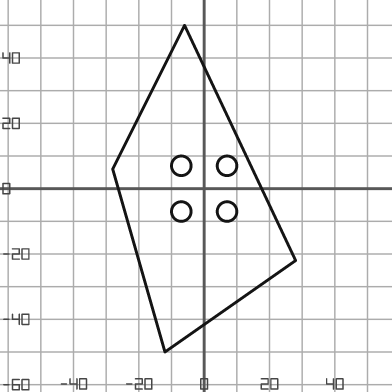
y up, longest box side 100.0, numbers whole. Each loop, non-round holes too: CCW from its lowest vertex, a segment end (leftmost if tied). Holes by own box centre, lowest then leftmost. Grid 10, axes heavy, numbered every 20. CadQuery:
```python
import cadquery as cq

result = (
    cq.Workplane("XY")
    .moveTo(-12.0, -50.0)
    .lineTo(28.0, -22.0)
    .lineTo(-6.0, 50.0)
    .lineTo(-28.0, 6.0)
    .close()
    .moveTo(-7.0, -7.0)
    .circle(3.0)
    .moveTo(7.0, -7.0)
    .circle(3.0)
    .moveTo(-7.0, 7.0)
    .circle(3.0)
    .moveTo(7.0, 7.0)
    .circle(3.0)
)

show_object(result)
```